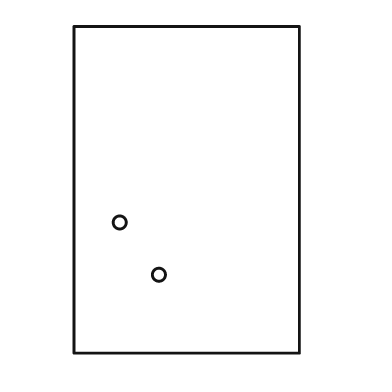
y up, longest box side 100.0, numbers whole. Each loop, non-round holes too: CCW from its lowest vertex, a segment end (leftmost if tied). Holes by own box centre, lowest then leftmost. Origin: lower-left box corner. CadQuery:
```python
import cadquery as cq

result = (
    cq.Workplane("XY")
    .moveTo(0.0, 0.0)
    .lineTo(69.0, 0.0)
    .lineTo(69.0, 100.0)
    .lineTo(0.0, 100.0)
    .close()
    .moveTo(26.0, 24.0)
    .circle(2.0)
    .moveTo(14.0, 40.0)
    .circle(2.0)
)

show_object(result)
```